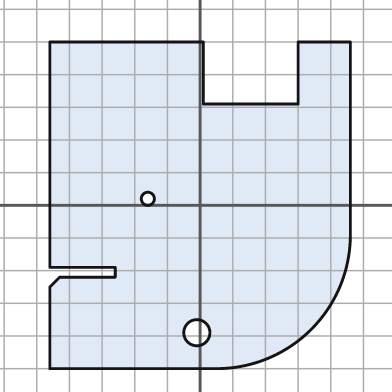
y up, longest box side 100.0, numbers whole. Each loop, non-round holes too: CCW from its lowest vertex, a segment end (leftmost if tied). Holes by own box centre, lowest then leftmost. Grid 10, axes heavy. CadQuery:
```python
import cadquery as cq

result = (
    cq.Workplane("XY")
    .moveTo(-46.0, -50.0)
    .lineTo(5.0, -50.0)
    .threePointArc((34.0, -38.0), (46.0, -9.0))
    .lineTo(46.0, 50.0)
    .lineTo(30.0, 50.0)
    .lineTo(30.0, 31.0)
    .lineTo(1.0, 31.0)
    .lineTo(1.0, 50.0)
    .lineTo(-46.0, 50.0)
    .lineTo(-46.0, -19.0)
    .lineTo(-26.0, -19.0)
    .lineTo(-26.0, -22.0)
    .lineTo(-43.0, -22.0)
    .lineTo(-46.0, -25.0)
    .close()
    .moveTo(-1.0, -39.0)
    .circle(4.0)
    .moveTo(-16.0, 2.0)
    .circle(2.0)
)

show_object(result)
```